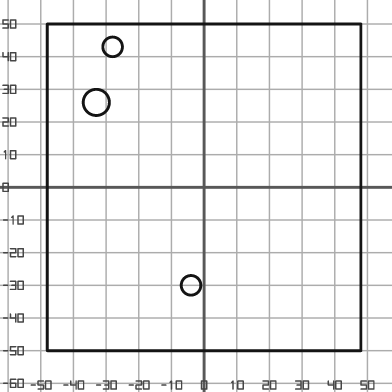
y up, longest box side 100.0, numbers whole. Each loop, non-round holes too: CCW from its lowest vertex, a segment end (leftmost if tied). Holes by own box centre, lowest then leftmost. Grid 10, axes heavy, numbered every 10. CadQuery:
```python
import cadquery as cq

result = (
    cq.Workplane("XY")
    .moveTo(-48.0, -50.0)
    .lineTo(48.0, -50.0)
    .lineTo(48.0, 50.0)
    .lineTo(-48.0, 50.0)
    .close()
    .moveTo(-4.0, -30.0)
    .circle(3.0)
    .moveTo(-33.0, 26.0)
    .circle(4.0)
    .moveTo(-28.0, 43.0)
    .circle(3.0)
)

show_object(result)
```